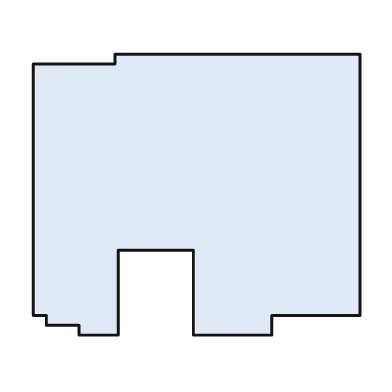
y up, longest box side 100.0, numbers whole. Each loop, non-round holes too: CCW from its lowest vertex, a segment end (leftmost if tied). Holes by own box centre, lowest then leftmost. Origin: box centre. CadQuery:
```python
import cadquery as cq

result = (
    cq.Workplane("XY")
    .moveTo(-36.0, -43.0)
    .lineTo(-24.0, -43.0)
    .lineTo(-24.0, -17.0)
    .lineTo(-1.0, -17.0)
    .lineTo(-1.0, -43.0)
    .lineTo(23.0, -43.0)
    .lineTo(23.0, -37.0)
    .lineTo(50.0, -37.0)
    .lineTo(50.0, 43.0)
    .lineTo(-25.0, 43.0)
    .lineTo(-25.0, 40.0)
    .lineTo(-50.0, 40.0)
    .lineTo(-50.0, -37.0)
    .lineTo(-46.0, -37.0)
    .lineTo(-46.0, -40.0)
    .lineTo(-36.0, -40.0)
    .close()
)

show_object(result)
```